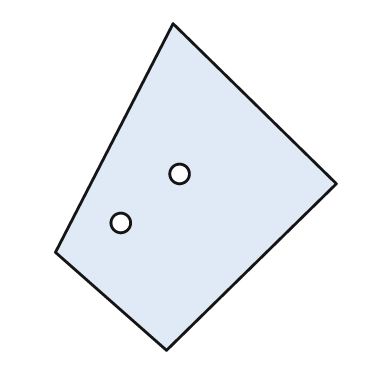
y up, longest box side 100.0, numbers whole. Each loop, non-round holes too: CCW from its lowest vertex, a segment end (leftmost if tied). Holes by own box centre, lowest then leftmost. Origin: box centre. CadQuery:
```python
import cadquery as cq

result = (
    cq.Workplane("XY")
    .moveTo(-9.0, -50.0)
    .lineTo(43.0, 1.0)
    .lineTo(-7.0, 50.0)
    .lineTo(-43.0, -20.0)
    .close()
    .moveTo(-23.0, -11.0)
    .circle(3.0)
    .moveTo(-5.0, 4.0)
    .circle(3.0)
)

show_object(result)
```